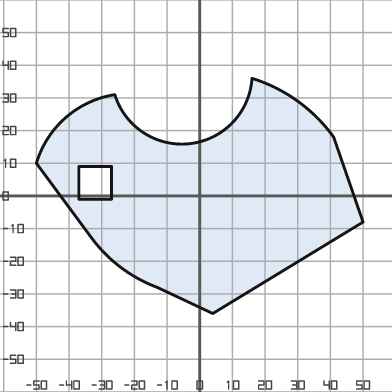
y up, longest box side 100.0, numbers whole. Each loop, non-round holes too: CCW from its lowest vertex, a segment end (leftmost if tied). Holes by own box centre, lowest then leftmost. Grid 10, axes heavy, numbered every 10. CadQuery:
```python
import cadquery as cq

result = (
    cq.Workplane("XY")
    .moveTo(4.0, -36.0)
    .lineTo(50.0, -8.0)
    .lineTo(41.0, 18.0)
    .threePointArc((30.0, 29.0), (16.0, 36.0))
    .threePointArc((-3.0, 16.0), (-26.0, 31.0))
    .threePointArc((-41.0, 24.0), (-50.0, 10.0))
    .lineTo(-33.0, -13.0)
    .threePointArc((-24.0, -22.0), (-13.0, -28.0))
    .close()
    .moveTo(-37.0, -1.0)
    .lineTo(-27.0, -1.0)
    .lineTo(-27.0, 9.0)
    .lineTo(-37.0, 9.0)
    .close()
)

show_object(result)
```